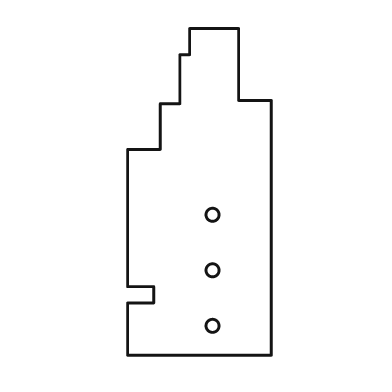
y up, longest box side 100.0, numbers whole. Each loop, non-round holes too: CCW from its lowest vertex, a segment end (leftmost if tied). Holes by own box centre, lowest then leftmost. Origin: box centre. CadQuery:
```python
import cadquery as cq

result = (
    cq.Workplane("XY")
    .moveTo(-22.0, -50.0)
    .lineTo(22.0, -50.0)
    .lineTo(22.0, 28.0)
    .lineTo(12.0, 28.0)
    .lineTo(12.0, 50.0)
    .lineTo(-3.0, 50.0)
    .lineTo(-3.0, 42.0)
    .lineTo(-6.0, 42.0)
    .lineTo(-6.0, 27.0)
    .lineTo(-12.0, 27.0)
    .lineTo(-12.0, 13.0)
    .lineTo(-22.0, 13.0)
    .lineTo(-22.0, -29.0)
    .lineTo(-14.0, -29.0)
    .lineTo(-14.0, -34.0)
    .lineTo(-22.0, -34.0)
    .close()
    .moveTo(4.0, -41.0)
    .circle(2.0)
    .moveTo(4.0, -24.0)
    .circle(2.0)
    .moveTo(4.0, -7.0)
    .circle(2.0)
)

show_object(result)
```